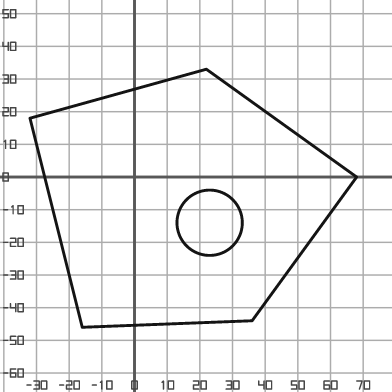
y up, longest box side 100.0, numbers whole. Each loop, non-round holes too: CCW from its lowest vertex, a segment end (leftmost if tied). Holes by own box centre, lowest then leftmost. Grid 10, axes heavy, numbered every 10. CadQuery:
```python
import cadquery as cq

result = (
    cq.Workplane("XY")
    .moveTo(-16.0, -46.0)
    .lineTo(36.0, -44.0)
    .lineTo(68.0, 0.0)
    .lineTo(22.0, 33.0)
    .lineTo(-32.0, 18.0)
    .close()
    .moveTo(23.0, -14.0)
    .circle(10.0)
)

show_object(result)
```